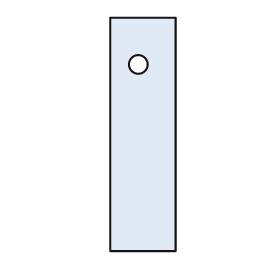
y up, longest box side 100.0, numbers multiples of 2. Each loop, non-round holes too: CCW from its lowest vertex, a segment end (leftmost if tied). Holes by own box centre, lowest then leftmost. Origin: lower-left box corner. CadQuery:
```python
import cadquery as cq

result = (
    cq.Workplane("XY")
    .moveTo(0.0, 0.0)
    .lineTo(28.0, 0.0)
    .lineTo(28.0, 100.0)
    .lineTo(0.0, 100.0)
    .close()
    .moveTo(12.0, 80.0)
    .circle(4.0)
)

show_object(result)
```